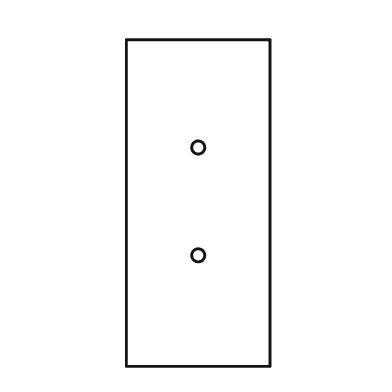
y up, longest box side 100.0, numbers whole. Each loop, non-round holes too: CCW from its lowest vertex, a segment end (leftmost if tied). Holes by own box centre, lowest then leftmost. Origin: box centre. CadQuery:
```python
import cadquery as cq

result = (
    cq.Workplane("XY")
    .moveTo(-22.0, -50.0)
    .lineTo(22.0, -50.0)
    .lineTo(22.0, 50.0)
    .lineTo(-22.0, 50.0)
    .close()
    .moveTo(0.0, -16.0)
    .circle(2.0)
    .moveTo(0.0, 17.0)
    .circle(2.0)
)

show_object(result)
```